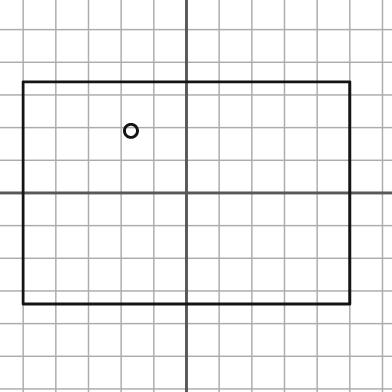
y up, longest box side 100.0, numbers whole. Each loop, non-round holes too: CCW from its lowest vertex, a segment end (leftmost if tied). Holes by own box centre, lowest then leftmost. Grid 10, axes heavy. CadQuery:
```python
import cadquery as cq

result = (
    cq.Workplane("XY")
    .moveTo(-50.0, -34.0)
    .lineTo(50.0, -34.0)
    .lineTo(50.0, 34.0)
    .lineTo(-50.0, 34.0)
    .close()
    .moveTo(-17.0, 19.0)
    .circle(2.0)
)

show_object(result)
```